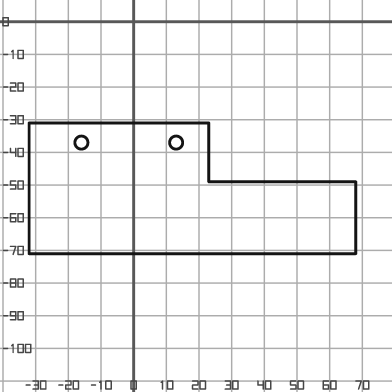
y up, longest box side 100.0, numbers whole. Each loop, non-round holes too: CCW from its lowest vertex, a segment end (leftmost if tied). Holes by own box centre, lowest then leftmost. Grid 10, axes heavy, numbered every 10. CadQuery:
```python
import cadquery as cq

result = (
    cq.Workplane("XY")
    .moveTo(-32.0, -71.0)
    .lineTo(68.0, -71.0)
    .lineTo(68.0, -49.0)
    .lineTo(23.0, -49.0)
    .lineTo(23.0, -31.0)
    .lineTo(-32.0, -31.0)
    .close()
    .moveTo(-16.0, -37.0)
    .circle(2.0)
    .moveTo(13.0, -37.0)
    .circle(2.0)
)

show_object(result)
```